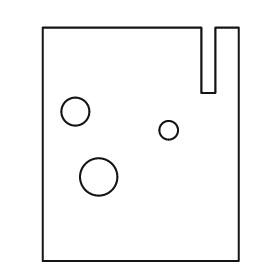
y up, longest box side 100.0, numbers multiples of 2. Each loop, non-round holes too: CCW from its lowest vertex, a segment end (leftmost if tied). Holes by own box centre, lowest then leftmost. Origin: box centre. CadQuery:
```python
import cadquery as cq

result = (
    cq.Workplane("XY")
    .moveTo(-42.0, -50.0)
    .lineTo(42.0, -50.0)
    .lineTo(42.0, 50.0)
    .lineTo(32.0, 50.0)
    .lineTo(32.0, 22.0)
    .lineTo(26.0, 22.0)
    .lineTo(26.0, 50.0)
    .lineTo(-42.0, 50.0)
    .close()
    .moveTo(-18.0, -14.0)
    .circle(8.0)
    .moveTo(12.0, 6.0)
    .circle(4.0)
    .moveTo(-28.0, 14.0)
    .circle(6.0)
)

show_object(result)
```